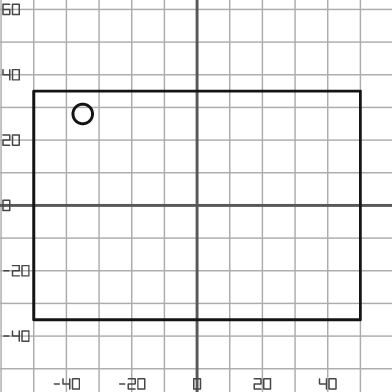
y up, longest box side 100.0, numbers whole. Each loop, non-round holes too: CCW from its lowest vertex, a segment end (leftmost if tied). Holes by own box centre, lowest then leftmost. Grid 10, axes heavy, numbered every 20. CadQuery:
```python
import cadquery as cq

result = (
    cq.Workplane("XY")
    .moveTo(-50.0, -35.0)
    .lineTo(50.0, -35.0)
    .lineTo(50.0, 35.0)
    .lineTo(-50.0, 35.0)
    .close()
    .moveTo(-35.0, 28.0)
    .circle(3.0)
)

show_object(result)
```